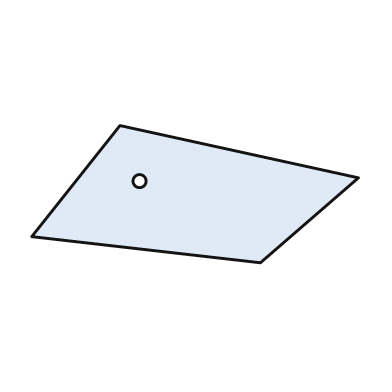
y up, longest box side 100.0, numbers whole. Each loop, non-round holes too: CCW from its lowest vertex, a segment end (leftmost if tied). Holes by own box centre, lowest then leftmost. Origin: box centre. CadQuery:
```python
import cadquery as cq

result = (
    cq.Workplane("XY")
    .moveTo(20.0, -21.0)
    .lineTo(50.0, 5.0)
    .lineTo(-23.0, 21.0)
    .lineTo(-50.0, -13.0)
    .close()
    .moveTo(-17.0, 4.0)
    .circle(2.0)
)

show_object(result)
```